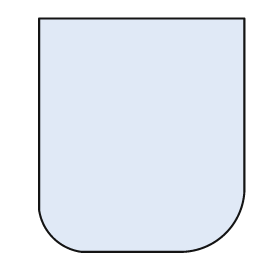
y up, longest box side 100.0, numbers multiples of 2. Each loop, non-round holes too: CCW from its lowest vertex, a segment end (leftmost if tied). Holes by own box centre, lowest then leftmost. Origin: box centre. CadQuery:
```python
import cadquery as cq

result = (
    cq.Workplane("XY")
    .moveTo(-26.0, -50.0)
    .lineTo(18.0, -50.0)
    .threePointArc((36.0, -42.0), (44.0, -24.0))
    .lineTo(44.0, 50.0)
    .lineTo(-44.0, 50.0)
    .lineTo(-44.0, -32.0)
    .threePointArc((-38.0, -44.0), (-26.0, -50.0))
    .close()
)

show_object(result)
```